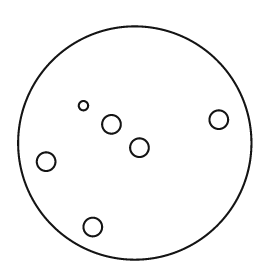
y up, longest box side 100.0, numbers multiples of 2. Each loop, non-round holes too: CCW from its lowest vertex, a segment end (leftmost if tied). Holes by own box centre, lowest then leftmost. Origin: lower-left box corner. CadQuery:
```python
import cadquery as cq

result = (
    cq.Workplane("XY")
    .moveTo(50.0, 50.0)
    .circle(50.0)
    .moveTo(32.0, 14.0)
    .circle(4.0)
    .moveTo(12.0, 42.0)
    .circle(4.0)
    .moveTo(52.0, 48.0)
    .circle(4.0)
    .moveTo(40.0, 58.0)
    .circle(4.0)
    .moveTo(86.0, 60.0)
    .circle(4.0)
    .moveTo(28.0, 66.0)
    .circle(2.0)
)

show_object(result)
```